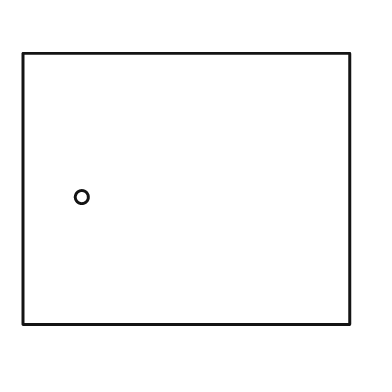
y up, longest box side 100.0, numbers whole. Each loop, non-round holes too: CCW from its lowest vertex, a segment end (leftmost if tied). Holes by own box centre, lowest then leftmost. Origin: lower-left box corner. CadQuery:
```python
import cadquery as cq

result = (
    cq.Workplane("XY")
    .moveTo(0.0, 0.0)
    .lineTo(100.0, 0.0)
    .lineTo(100.0, 83.0)
    .lineTo(0.0, 83.0)
    .close()
    .moveTo(18.0, 39.0)
    .circle(2.0)
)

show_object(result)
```